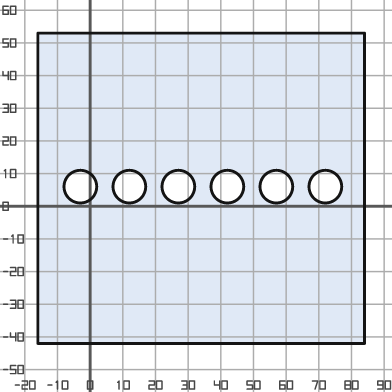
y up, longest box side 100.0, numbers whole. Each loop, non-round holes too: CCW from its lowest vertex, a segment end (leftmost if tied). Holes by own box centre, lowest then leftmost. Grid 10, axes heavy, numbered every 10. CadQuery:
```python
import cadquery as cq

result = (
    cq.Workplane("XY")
    .moveTo(-16.0, -42.0)
    .lineTo(84.0, -42.0)
    .lineTo(84.0, 53.0)
    .lineTo(-16.0, 53.0)
    .close()
    .moveTo(-3.0, 6.0)
    .circle(5.0)
    .moveTo(12.0, 6.0)
    .circle(5.0)
    .moveTo(27.0, 6.0)
    .circle(5.0)
    .moveTo(42.0, 6.0)
    .circle(5.0)
    .moveTo(57.0, 6.0)
    .circle(5.0)
    .moveTo(72.0, 6.0)
    .circle(5.0)
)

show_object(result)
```